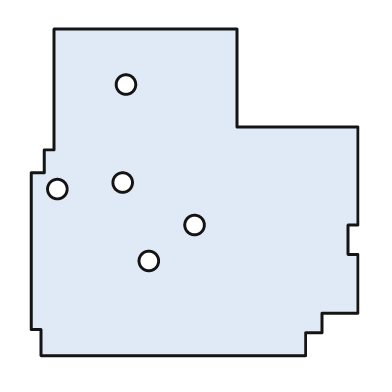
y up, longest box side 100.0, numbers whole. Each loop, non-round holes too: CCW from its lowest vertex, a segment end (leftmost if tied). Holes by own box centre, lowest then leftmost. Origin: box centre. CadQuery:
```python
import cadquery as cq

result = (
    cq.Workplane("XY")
    .moveTo(-47.0, -50.0)
    .lineTo(34.0, -50.0)
    .lineTo(34.0, -43.0)
    .lineTo(39.0, -43.0)
    .lineTo(39.0, -37.0)
    .lineTo(50.0, -37.0)
    .lineTo(50.0, -19.0)
    .lineTo(47.0, -19.0)
    .lineTo(47.0, -10.0)
    .lineTo(50.0, -10.0)
    .lineTo(50.0, 20.0)
    .lineTo(13.0, 20.0)
    .lineTo(13.0, 50.0)
    .lineTo(-43.0, 50.0)
    .lineTo(-43.0, 13.0)
    .lineTo(-46.0, 13.0)
    .lineTo(-46.0, 6.0)
    .lineTo(-50.0, 6.0)
    .lineTo(-50.0, -42.0)
    .lineTo(-47.0, -42.0)
    .close()
    .moveTo(-14.0, -21.0)
    .circle(3.0)
    .moveTo(0.0, -10.0)
    .circle(3.0)
    .moveTo(-42.0, 1.0)
    .circle(3.0)
    .moveTo(-22.0, 3.0)
    .circle(3.0)
    .moveTo(-21.0, 33.0)
    .circle(3.0)
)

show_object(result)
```